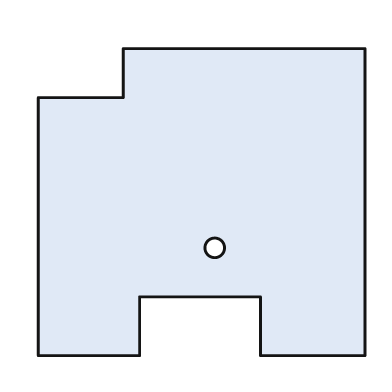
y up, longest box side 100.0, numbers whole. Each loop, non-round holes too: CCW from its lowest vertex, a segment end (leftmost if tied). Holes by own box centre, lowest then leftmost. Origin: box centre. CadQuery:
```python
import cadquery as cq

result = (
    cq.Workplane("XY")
    .moveTo(-50.0, -47.0)
    .lineTo(-19.0, -47.0)
    .lineTo(-19.0, -29.0)
    .lineTo(18.0, -29.0)
    .lineTo(18.0, -47.0)
    .lineTo(50.0, -47.0)
    .lineTo(50.0, 47.0)
    .lineTo(-24.0, 47.0)
    .lineTo(-24.0, 32.0)
    .lineTo(-50.0, 32.0)
    .close()
    .moveTo(4.0, -14.0)
    .circle(3.0)
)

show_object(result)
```